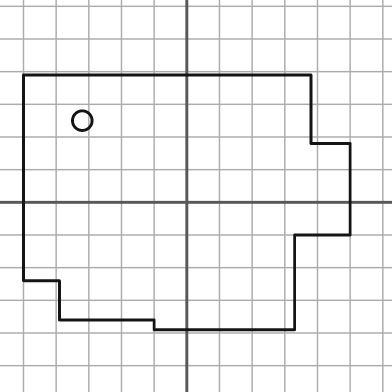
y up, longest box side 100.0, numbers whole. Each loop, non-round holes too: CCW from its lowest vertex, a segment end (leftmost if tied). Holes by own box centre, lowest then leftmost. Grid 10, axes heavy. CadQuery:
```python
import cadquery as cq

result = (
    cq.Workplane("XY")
    .moveTo(-10.0, -39.0)
    .lineTo(33.0, -39.0)
    .lineTo(33.0, -10.0)
    .lineTo(50.0, -10.0)
    .lineTo(50.0, 18.0)
    .lineTo(38.0, 18.0)
    .lineTo(38.0, 39.0)
    .lineTo(-50.0, 39.0)
    .lineTo(-50.0, -24.0)
    .lineTo(-39.0, -24.0)
    .lineTo(-39.0, -36.0)
    .lineTo(-10.0, -36.0)
    .close()
    .moveTo(-32.0, 25.0)
    .circle(3.0)
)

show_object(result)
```